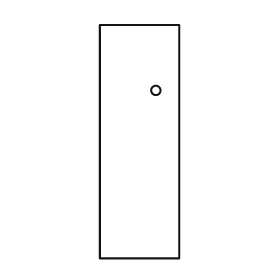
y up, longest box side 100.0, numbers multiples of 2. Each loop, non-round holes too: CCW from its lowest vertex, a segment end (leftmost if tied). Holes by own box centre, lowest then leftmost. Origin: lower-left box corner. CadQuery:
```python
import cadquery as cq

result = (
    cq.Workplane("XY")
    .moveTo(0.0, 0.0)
    .lineTo(34.0, 0.0)
    .lineTo(34.0, 100.0)
    .lineTo(0.0, 100.0)
    .close()
    .moveTo(24.0, 72.0)
    .circle(2.0)
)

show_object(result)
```